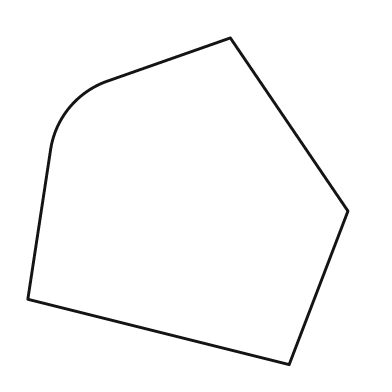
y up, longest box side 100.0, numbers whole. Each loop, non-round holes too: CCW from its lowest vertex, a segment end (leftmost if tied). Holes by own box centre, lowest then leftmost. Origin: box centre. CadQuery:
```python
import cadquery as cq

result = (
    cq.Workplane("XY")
    .moveTo(31.0, -50.0)
    .lineTo(49.0, -3.0)
    .lineTo(13.0, 50.0)
    .lineTo(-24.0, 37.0)
    .threePointArc((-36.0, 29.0), (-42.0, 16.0))
    .lineTo(-49.0, -30.0)
    .close()
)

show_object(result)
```